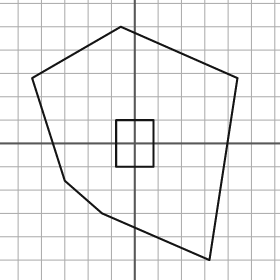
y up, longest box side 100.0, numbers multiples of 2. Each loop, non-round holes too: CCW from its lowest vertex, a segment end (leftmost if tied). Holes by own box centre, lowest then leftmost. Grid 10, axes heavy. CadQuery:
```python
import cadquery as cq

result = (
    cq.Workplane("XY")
    .moveTo(32.0, -50.0)
    .lineTo(44.0, 28.0)
    .lineTo(-6.0, 50.0)
    .lineTo(-44.0, 28.0)
    .lineTo(-30.0, -16.0)
    .lineTo(-14.0, -30.0)
    .close()
    .moveTo(-8.0, -10.0)
    .lineTo(8.0, -10.0)
    .lineTo(8.0, 10.0)
    .lineTo(-8.0, 10.0)
    .close()
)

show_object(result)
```